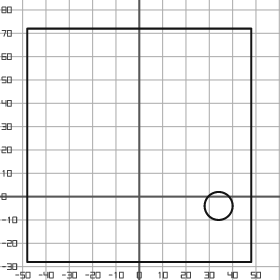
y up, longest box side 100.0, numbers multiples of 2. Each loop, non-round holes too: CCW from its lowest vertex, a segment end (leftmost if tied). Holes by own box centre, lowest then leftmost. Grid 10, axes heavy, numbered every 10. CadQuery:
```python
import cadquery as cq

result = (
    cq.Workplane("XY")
    .moveTo(-48.0, -28.0)
    .lineTo(48.0, -28.0)
    .lineTo(48.0, 72.0)
    .lineTo(-48.0, 72.0)
    .close()
    .moveTo(34.0, -4.0)
    .circle(6.0)
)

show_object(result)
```